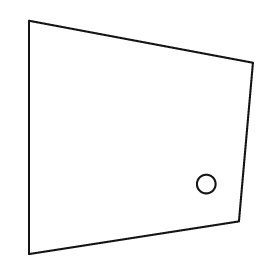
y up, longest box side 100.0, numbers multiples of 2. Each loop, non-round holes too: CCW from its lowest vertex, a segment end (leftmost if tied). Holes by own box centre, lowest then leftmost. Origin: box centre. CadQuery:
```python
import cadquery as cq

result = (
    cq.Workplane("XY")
    .moveTo(-48.0, -50.0)
    .lineTo(42.0, -36.0)
    .lineTo(48.0, 32.0)
    .lineTo(-48.0, 50.0)
    .close()
    .moveTo(28.0, -20.0)
    .circle(4.0)
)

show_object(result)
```